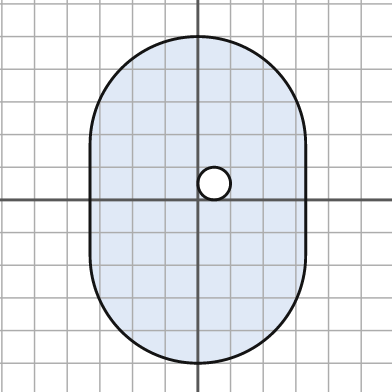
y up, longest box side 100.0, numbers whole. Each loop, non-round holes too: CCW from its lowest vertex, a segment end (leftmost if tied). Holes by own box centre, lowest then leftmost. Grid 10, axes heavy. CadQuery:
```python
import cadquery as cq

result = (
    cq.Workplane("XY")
    .moveTo(-33.0, -17.0)
    .threePointArc((0.0, -50.0), (33.0, -17.0))
    .lineTo(33.0, 17.0)
    .threePointArc((0.0, 50.0), (-33.0, 17.0))
    .close()
    .moveTo(5.0, 5.0)
    .circle(5.0)
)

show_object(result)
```